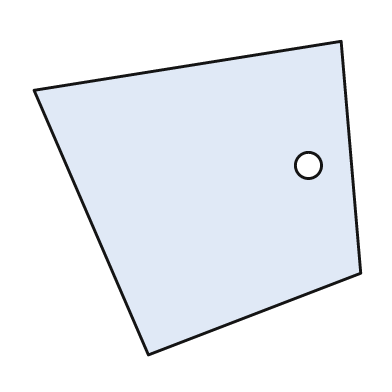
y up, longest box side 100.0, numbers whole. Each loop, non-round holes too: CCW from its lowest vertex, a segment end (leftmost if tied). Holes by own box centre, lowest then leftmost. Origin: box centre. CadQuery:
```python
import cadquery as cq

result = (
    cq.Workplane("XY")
    .moveTo(-15.0, -48.0)
    .lineTo(50.0, -23.0)
    .lineTo(44.0, 48.0)
    .lineTo(-50.0, 33.0)
    .close()
    .moveTo(34.0, 10.0)
    .circle(4.0)
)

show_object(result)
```